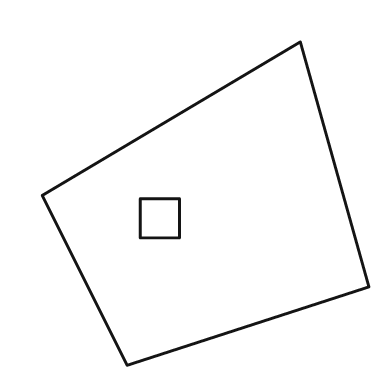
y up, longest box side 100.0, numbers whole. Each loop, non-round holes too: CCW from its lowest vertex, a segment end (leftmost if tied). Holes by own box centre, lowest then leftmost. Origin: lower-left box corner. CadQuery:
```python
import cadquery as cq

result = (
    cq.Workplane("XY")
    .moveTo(26.0, 0.0)
    .lineTo(100.0, 24.0)
    .lineTo(79.0, 99.0)
    .lineTo(0.0, 52.0)
    .close()
    .moveTo(30.0, 39.0)
    .lineTo(42.0, 39.0)
    .lineTo(42.0, 51.0)
    .lineTo(30.0, 51.0)
    .close()
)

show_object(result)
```